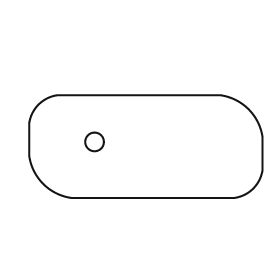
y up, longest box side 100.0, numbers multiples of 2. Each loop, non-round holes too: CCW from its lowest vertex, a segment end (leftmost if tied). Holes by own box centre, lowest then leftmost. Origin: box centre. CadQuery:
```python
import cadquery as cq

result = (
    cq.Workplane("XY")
    .moveTo(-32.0, -22.0)
    .lineTo(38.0, -22.0)
    .threePointArc((46.0, -18.0), (50.0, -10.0))
    .lineTo(50.0, 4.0)
    .threePointArc((44.0, 16.0), (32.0, 22.0))
    .lineTo(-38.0, 22.0)
    .threePointArc((-46.0, 18.0), (-50.0, 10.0))
    .lineTo(-50.0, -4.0)
    .threePointArc((-44.0, -16.0), (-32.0, -22.0))
    .close()
    .moveTo(-22.0, 2.0)
    .circle(4.0)
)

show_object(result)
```